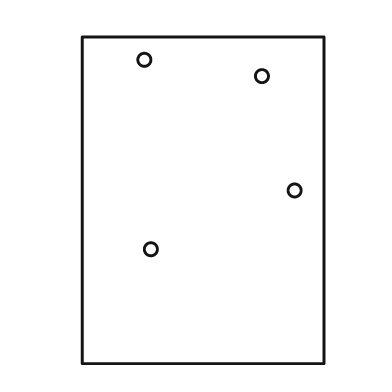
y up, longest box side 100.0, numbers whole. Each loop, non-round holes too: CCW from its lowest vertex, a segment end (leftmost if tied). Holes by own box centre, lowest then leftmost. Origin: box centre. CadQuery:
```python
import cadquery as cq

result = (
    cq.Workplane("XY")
    .moveTo(-37.0, -50.0)
    .lineTo(37.0, -50.0)
    .lineTo(37.0, 50.0)
    .lineTo(-37.0, 50.0)
    .close()
    .moveTo(-16.0, -15.0)
    .circle(2.0)
    .moveTo(28.0, 3.0)
    .circle(2.0)
    .moveTo(18.0, 38.0)
    .circle(2.0)
    .moveTo(-18.0, 43.0)
    .circle(2.0)
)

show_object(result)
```